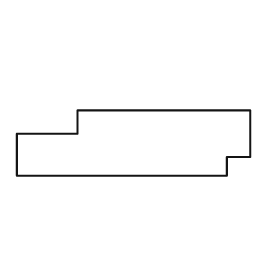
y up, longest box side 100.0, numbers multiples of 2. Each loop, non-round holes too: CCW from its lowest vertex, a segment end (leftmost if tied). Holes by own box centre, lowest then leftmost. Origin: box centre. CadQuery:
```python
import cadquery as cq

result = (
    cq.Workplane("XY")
    .moveTo(-50.0, -14.0)
    .lineTo(40.0, -14.0)
    .lineTo(40.0, -6.0)
    .lineTo(50.0, -6.0)
    .lineTo(50.0, 14.0)
    .lineTo(-24.0, 14.0)
    .lineTo(-24.0, 4.0)
    .lineTo(-50.0, 4.0)
    .close()
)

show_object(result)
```